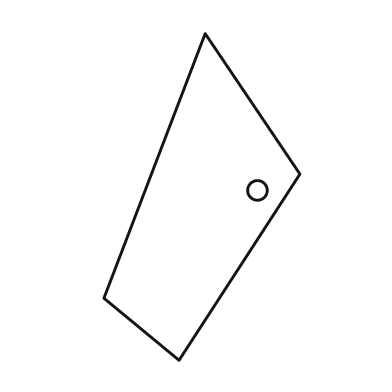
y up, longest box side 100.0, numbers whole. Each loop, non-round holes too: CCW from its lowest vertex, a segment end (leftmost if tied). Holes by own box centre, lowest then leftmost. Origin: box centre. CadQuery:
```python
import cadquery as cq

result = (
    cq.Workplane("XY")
    .moveTo(-7.0, -50.0)
    .lineTo(30.0, 7.0)
    .lineTo(1.0, 50.0)
    .lineTo(-30.0, -31.0)
    .close()
    .moveTo(17.0, 2.0)
    .circle(3.0)
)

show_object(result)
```